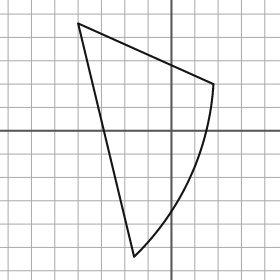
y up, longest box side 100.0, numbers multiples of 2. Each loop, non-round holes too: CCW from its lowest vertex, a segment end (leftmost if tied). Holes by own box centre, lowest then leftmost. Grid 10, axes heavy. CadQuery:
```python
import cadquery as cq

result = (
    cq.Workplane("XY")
    .moveTo(-16.0, -54.0)
    .threePointArc((8.0, -20.0), (18.0, 20.0))
    .lineTo(-40.0, 46.0)
    .close()
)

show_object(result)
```